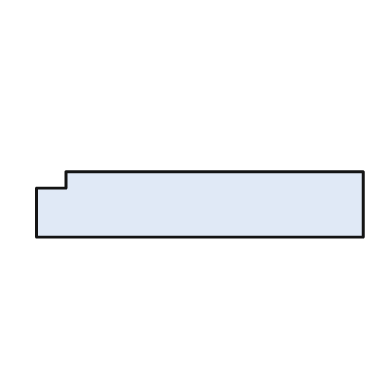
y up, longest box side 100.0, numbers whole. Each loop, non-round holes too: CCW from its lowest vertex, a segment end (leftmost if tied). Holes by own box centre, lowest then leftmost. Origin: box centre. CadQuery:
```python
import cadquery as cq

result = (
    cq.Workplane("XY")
    .moveTo(-50.0, -10.0)
    .lineTo(50.0, -10.0)
    .lineTo(50.0, 10.0)
    .lineTo(-41.0, 10.0)
    .lineTo(-41.0, 5.0)
    .lineTo(-50.0, 5.0)
    .close()
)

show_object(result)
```